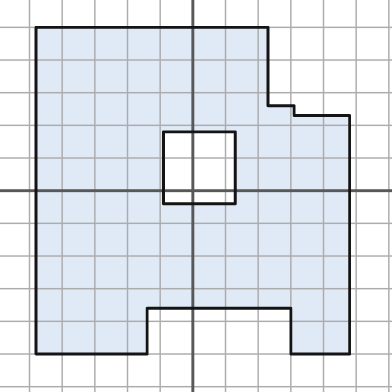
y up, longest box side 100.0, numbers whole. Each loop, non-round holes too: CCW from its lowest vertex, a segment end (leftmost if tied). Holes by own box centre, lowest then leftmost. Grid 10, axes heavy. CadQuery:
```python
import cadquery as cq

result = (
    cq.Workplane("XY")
    .moveTo(-48.0, -50.0)
    .lineTo(-14.0, -50.0)
    .lineTo(-14.0, -36.0)
    .lineTo(30.0, -36.0)
    .lineTo(30.0, -50.0)
    .lineTo(48.0, -50.0)
    .lineTo(48.0, 23.0)
    .lineTo(31.0, 23.0)
    .lineTo(31.0, 26.0)
    .lineTo(23.0, 26.0)
    .lineTo(23.0, 50.0)
    .lineTo(-48.0, 50.0)
    .close()
    .moveTo(-9.0, -4.0)
    .lineTo(13.0, -4.0)
    .lineTo(13.0, 18.0)
    .lineTo(-9.0, 18.0)
    .close()
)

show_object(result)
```